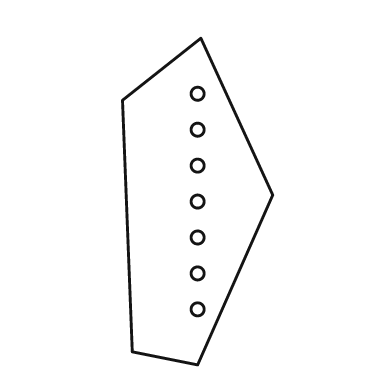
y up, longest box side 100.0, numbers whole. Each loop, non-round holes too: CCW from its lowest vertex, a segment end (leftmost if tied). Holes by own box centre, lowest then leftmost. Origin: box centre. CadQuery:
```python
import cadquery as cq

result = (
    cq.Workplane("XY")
    .moveTo(0.0, -50.0)
    .lineTo(23.0, 2.0)
    .lineTo(1.0, 50.0)
    .lineTo(-23.0, 31.0)
    .lineTo(-20.0, -46.0)
    .close()
    .moveTo(0.0, -33.0)
    .circle(2.0)
    .moveTo(0.0, -22.0)
    .circle(2.0)
    .moveTo(0.0, -11.0)
    .circle(2.0)
    .moveTo(0.0, 0.0)
    .circle(2.0)
    .moveTo(0.0, 11.0)
    .circle(2.0)
    .moveTo(0.0, 22.0)
    .circle(2.0)
    .moveTo(0.0, 33.0)
    .circle(2.0)
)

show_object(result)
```